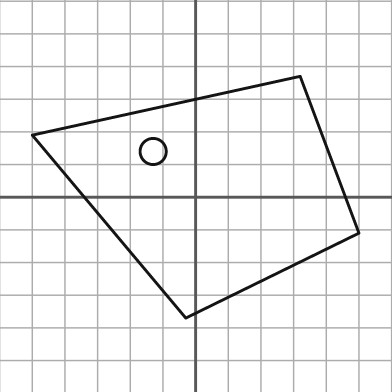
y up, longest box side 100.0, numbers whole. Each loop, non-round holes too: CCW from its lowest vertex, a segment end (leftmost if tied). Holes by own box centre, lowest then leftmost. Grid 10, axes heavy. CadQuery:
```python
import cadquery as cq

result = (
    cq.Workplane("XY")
    .moveTo(-3.0, -37.0)
    .lineTo(50.0, -11.0)
    .lineTo(32.0, 37.0)
    .lineTo(-50.0, 19.0)
    .close()
    .moveTo(-13.0, 14.0)
    .circle(4.0)
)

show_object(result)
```